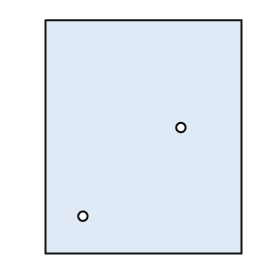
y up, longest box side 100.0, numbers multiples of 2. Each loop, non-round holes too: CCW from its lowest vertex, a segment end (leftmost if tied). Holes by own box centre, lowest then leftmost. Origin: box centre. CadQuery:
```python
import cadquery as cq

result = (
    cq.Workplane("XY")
    .moveTo(-42.0, -50.0)
    .lineTo(42.0, -50.0)
    .lineTo(42.0, 50.0)
    .lineTo(-42.0, 50.0)
    .close()
    .moveTo(-26.0, -34.0)
    .circle(2.0)
    .moveTo(16.0, 4.0)
    .circle(2.0)
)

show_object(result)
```